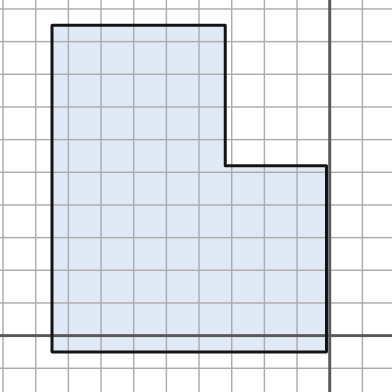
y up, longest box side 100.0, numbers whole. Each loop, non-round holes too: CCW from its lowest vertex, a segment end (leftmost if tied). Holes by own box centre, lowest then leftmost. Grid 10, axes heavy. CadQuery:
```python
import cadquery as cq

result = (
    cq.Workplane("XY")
    .moveTo(-85.0, -5.0)
    .lineTo(-1.0, -5.0)
    .lineTo(-1.0, 52.0)
    .lineTo(-32.0, 52.0)
    .lineTo(-32.0, 95.0)
    .lineTo(-85.0, 95.0)
    .close()
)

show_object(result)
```